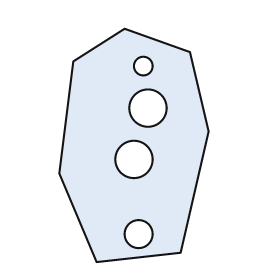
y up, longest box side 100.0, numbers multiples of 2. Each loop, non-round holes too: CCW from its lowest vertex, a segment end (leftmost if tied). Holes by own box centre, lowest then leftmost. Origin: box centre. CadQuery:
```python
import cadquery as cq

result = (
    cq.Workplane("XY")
    .moveTo(-16.0, -50.0)
    .lineTo(20.0, -46.0)
    .lineTo(32.0, 6.0)
    .lineTo(24.0, 40.0)
    .lineTo(-4.0, 50.0)
    .lineTo(-26.0, 36.0)
    .lineTo(-32.0, -12.0)
    .close()
    .moveTo(2.0, -38.0)
    .circle(6.0)
    .moveTo(0.0, -6.0)
    .circle(8.0)
    .moveTo(6.0, 16.0)
    .circle(8.0)
    .moveTo(4.0, 34.0)
    .circle(4.0)
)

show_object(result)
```